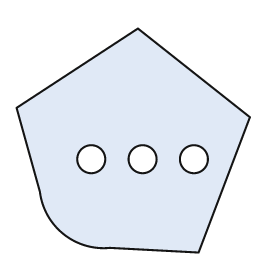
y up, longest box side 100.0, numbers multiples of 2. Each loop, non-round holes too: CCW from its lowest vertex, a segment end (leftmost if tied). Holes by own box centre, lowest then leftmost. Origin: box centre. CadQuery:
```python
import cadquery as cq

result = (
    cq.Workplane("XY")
    .moveTo(28.0, -48.0)
    .lineTo(50.0, 10.0)
    .lineTo(2.0, 48.0)
    .lineTo(-50.0, 14.0)
    .lineTo(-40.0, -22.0)
    .threePointArc((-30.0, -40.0), (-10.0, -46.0))
    .close()
    .moveTo(-18.0, -8.0)
    .circle(6.0)
    .moveTo(4.0, -8.0)
    .circle(6.0)
    .moveTo(26.0, -8.0)
    .circle(6.0)
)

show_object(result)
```